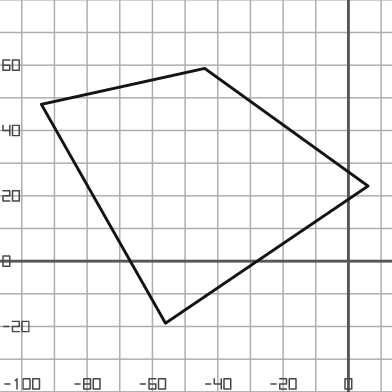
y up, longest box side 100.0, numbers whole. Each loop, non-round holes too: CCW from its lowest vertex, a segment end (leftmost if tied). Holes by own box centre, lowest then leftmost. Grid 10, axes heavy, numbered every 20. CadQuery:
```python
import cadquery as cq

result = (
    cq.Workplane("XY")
    .moveTo(-56.0, -19.0)
    .lineTo(6.0, 23.0)
    .lineTo(-44.0, 59.0)
    .lineTo(-94.0, 48.0)
    .close()
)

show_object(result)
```